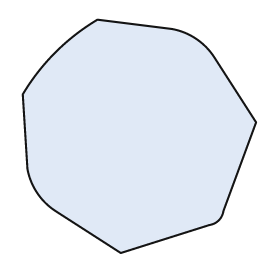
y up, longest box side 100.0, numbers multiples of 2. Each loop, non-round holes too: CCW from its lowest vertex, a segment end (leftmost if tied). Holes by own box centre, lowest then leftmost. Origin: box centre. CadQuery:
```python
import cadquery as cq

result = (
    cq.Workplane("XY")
    .moveTo(-8.0, -50.0)
    .lineTo(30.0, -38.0)
    .threePointArc((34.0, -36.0), (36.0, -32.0))
    .lineTo(50.0, 6.0)
    .lineTo(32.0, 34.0)
    .threePointArc((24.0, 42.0), (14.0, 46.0))
    .lineTo(-18.0, 50.0)
    .threePointArc((-36.0, 36.0), (-50.0, 18.0))
    .lineTo(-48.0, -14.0)
    .threePointArc((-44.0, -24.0), (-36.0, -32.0))
    .close()
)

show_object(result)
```